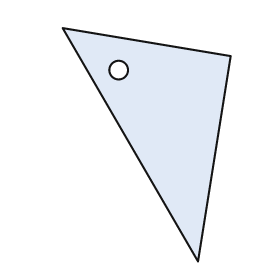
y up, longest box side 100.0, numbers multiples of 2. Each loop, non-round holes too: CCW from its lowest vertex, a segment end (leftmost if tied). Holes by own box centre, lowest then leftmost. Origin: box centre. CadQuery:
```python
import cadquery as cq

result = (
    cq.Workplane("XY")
    .moveTo(22.0, -50.0)
    .lineTo(36.0, 38.0)
    .lineTo(-36.0, 50.0)
    .close()
    .moveTo(-12.0, 32.0)
    .circle(4.0)
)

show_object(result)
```